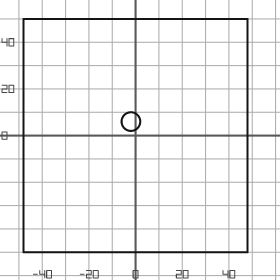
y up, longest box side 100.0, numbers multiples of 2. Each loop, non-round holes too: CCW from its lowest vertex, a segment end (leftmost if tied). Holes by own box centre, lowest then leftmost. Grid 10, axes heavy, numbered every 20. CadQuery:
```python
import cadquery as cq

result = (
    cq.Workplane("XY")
    .moveTo(-48.0, -50.0)
    .lineTo(48.0, -50.0)
    .lineTo(48.0, 50.0)
    .lineTo(-48.0, 50.0)
    .close()
    .moveTo(-2.0, 6.0)
    .circle(4.0)
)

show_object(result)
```